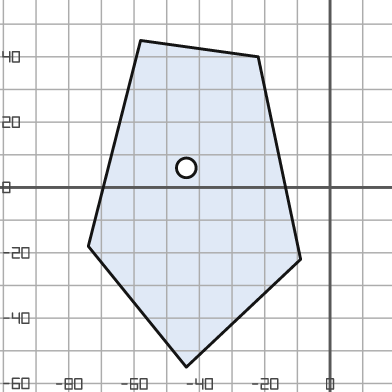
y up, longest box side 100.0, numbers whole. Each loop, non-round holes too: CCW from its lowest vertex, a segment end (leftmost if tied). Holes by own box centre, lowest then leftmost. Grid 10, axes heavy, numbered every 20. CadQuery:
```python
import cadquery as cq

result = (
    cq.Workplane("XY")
    .moveTo(-44.0, -55.0)
    .lineTo(-9.0, -22.0)
    .lineTo(-22.0, 40.0)
    .lineTo(-58.0, 45.0)
    .lineTo(-74.0, -18.0)
    .close()
    .moveTo(-44.0, 6.0)
    .circle(3.0)
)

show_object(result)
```